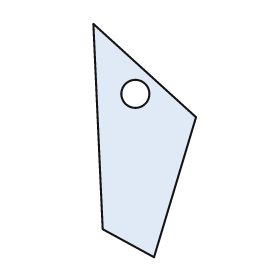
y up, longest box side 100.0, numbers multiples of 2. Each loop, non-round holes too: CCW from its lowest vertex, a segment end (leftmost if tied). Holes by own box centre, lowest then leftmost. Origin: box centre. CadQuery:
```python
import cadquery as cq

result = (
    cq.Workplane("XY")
    .moveTo(4.0, -50.0)
    .lineTo(22.0, 10.0)
    .lineTo(-22.0, 50.0)
    .lineTo(-18.0, -38.0)
    .close()
    .moveTo(-4.0, 20.0)
    .circle(6.0)
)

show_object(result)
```